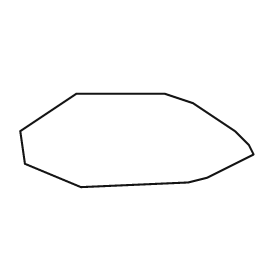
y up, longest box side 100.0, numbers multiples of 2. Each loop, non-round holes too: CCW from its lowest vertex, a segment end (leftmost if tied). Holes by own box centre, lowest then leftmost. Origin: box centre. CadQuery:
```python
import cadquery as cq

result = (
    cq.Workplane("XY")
    .moveTo(-24.0, -20.0)
    .lineTo(22.0, -18.0)
    .lineTo(30.0, -16.0)
    .lineTo(50.0, -6.0)
    .lineTo(48.0, -2.0)
    .lineTo(42.0, 4.0)
    .lineTo(24.0, 16.0)
    .lineTo(12.0, 20.0)
    .lineTo(-26.0, 20.0)
    .lineTo(-50.0, 4.0)
    .lineTo(-48.0, -10.0)
    .close()
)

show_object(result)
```